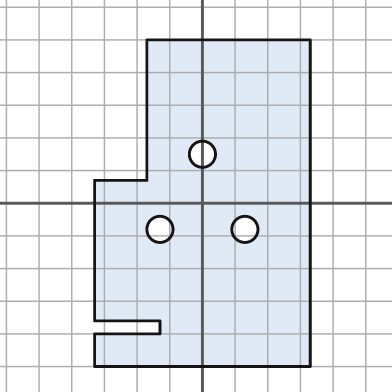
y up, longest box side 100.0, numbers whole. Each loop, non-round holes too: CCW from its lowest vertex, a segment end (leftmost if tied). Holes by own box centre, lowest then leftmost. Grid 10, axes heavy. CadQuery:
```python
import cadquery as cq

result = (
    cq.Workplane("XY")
    .moveTo(-33.0, -50.0)
    .lineTo(33.0, -50.0)
    .lineTo(33.0, 50.0)
    .lineTo(-17.0, 50.0)
    .lineTo(-17.0, 7.0)
    .lineTo(-33.0, 7.0)
    .lineTo(-33.0, -36.0)
    .lineTo(-13.0, -36.0)
    .lineTo(-13.0, -40.0)
    .lineTo(-33.0, -40.0)
    .close()
    .moveTo(-13.0, -8.0)
    .circle(4.0)
    .moveTo(13.0, -8.0)
    .circle(4.0)
    .moveTo(0.0, 15.0)
    .circle(4.0)
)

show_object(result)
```